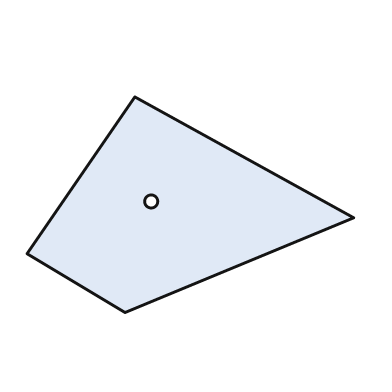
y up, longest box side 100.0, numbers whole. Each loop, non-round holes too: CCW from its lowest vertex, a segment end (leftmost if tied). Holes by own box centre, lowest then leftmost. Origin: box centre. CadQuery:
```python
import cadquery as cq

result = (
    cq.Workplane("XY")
    .moveTo(-20.0, -33.0)
    .lineTo(50.0, -4.0)
    .lineTo(-17.0, 33.0)
    .lineTo(-50.0, -15.0)
    .close()
    .moveTo(-12.0, 1.0)
    .circle(2.0)
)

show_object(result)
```